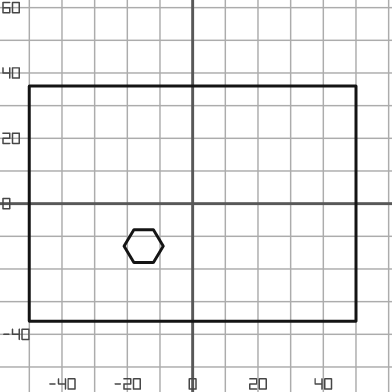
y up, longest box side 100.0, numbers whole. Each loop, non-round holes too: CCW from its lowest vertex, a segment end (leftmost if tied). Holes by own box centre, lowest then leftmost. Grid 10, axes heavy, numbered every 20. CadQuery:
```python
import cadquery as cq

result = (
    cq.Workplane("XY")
    .moveTo(-50.0, -36.0)
    .lineTo(50.0, -36.0)
    .lineTo(50.0, 36.0)
    .lineTo(-50.0, 36.0)
    .close()
    .moveTo(-18.0, -18.0)
    .lineTo(-12.0, -18.0)
    .lineTo(-9.0, -13.0)
    .lineTo(-12.0, -8.0)
    .lineTo(-18.0, -8.0)
    .lineTo(-21.0, -13.0)
    .close()
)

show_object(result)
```